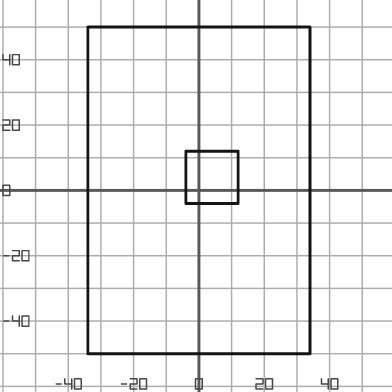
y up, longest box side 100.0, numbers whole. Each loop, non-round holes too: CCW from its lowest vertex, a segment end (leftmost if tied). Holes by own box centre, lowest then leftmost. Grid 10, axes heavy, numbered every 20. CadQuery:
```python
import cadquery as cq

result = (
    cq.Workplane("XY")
    .moveTo(-34.0, -50.0)
    .lineTo(34.0, -50.0)
    .lineTo(34.0, 50.0)
    .lineTo(-34.0, 50.0)
    .close()
    .moveTo(-4.0, -4.0)
    .lineTo(12.0, -4.0)
    .lineTo(12.0, 12.0)
    .lineTo(-4.0, 12.0)
    .close()
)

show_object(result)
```